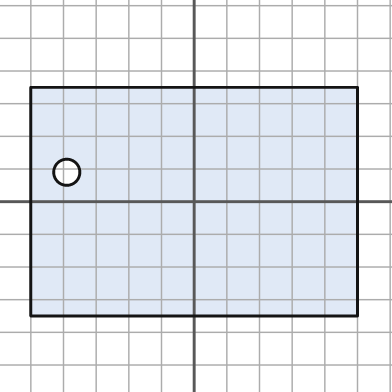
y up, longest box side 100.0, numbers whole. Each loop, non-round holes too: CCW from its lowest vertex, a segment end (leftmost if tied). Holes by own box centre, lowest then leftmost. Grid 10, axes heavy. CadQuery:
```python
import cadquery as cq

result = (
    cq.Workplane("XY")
    .moveTo(-50.0, -35.0)
    .lineTo(50.0, -35.0)
    .lineTo(50.0, 35.0)
    .lineTo(-50.0, 35.0)
    .close()
    .moveTo(-39.0, 9.0)
    .circle(4.0)
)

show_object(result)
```